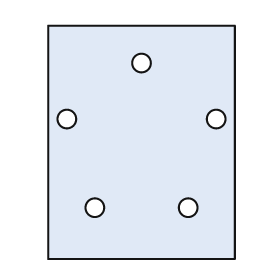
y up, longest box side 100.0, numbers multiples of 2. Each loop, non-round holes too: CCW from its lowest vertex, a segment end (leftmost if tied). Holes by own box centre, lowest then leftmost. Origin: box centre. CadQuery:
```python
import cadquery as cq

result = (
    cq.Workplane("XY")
    .moveTo(-40.0, -50.0)
    .lineTo(40.0, -50.0)
    .lineTo(40.0, 50.0)
    .lineTo(-40.0, 50.0)
    .close()
    .moveTo(-20.0, -28.0)
    .circle(4.0)
    .moveTo(20.0, -28.0)
    .circle(4.0)
    .moveTo(-32.0, 10.0)
    .circle(4.0)
    .moveTo(32.0, 10.0)
    .circle(4.0)
    .moveTo(0.0, 34.0)
    .circle(4.0)
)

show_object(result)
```